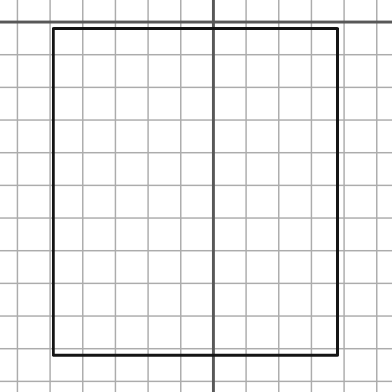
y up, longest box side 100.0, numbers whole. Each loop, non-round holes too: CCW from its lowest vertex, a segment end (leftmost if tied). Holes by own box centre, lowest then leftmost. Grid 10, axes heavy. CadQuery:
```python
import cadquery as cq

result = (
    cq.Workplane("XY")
    .moveTo(-49.0, -102.0)
    .lineTo(38.0, -102.0)
    .lineTo(38.0, -2.0)
    .lineTo(-49.0, -2.0)
    .close()
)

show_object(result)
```